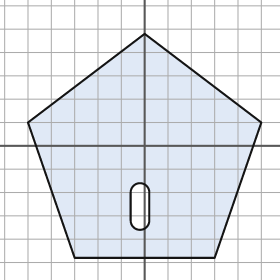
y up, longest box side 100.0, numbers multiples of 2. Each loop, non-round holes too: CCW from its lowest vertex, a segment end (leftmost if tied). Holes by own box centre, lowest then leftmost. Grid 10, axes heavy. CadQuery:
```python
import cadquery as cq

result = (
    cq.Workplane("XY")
    .moveTo(-30.0, -48.0)
    .lineTo(30.0, -48.0)
    .lineTo(50.0, 10.0)
    .lineTo(0.0, 48.0)
    .lineTo(-50.0, 10.0)
    .close()
    .moveTo(-6.0, -32.0)
    .threePointArc((-2.0, -36.0), (2.0, -32.0))
    .lineTo(2.0, -20.0)
    .threePointArc((-2.0, -16.0), (-6.0, -20.0))
    .close()
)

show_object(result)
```